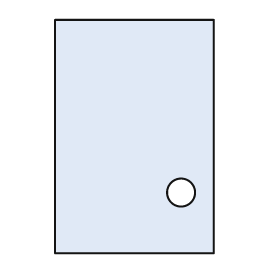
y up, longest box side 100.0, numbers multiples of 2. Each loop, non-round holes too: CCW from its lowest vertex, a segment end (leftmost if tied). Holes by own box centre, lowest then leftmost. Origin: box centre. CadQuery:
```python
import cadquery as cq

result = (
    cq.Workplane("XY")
    .moveTo(-34.0, -50.0)
    .lineTo(34.0, -50.0)
    .lineTo(34.0, 50.0)
    .lineTo(-34.0, 50.0)
    .close()
    .moveTo(20.0, -24.0)
    .circle(6.0)
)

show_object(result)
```